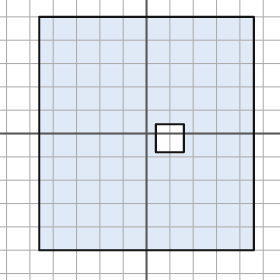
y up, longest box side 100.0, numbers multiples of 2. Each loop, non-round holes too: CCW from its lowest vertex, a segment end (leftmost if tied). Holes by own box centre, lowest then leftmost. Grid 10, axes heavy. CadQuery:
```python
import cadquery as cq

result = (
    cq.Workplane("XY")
    .moveTo(-46.0, -50.0)
    .lineTo(46.0, -50.0)
    .lineTo(46.0, 50.0)
    .lineTo(-46.0, 50.0)
    .close()
    .moveTo(4.0, -8.0)
    .lineTo(16.0, -8.0)
    .lineTo(16.0, 4.0)
    .lineTo(4.0, 4.0)
    .close()
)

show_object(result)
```